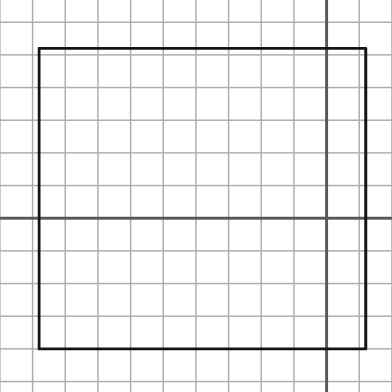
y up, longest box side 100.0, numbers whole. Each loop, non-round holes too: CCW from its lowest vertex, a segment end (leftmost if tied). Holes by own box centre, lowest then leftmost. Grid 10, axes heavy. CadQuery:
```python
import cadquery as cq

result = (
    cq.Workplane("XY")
    .moveTo(-88.0, -40.0)
    .lineTo(12.0, -40.0)
    .lineTo(12.0, 52.0)
    .lineTo(-88.0, 52.0)
    .close()
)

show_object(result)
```